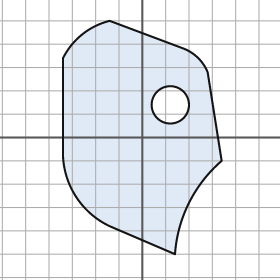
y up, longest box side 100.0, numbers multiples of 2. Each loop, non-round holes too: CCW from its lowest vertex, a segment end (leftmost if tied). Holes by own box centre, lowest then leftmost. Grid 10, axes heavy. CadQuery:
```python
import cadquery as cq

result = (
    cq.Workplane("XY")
    .moveTo(14.0, -50.0)
    .threePointArc((20.0, -28.0), (34.0, -10.0))
    .lineTo(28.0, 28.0)
    .threePointArc((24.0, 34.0), (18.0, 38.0))
    .lineTo(-14.0, 50.0)
    .threePointArc((-26.0, 44.0), (-34.0, 34.0))
    .lineTo(-34.0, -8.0)
    .threePointArc((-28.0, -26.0), (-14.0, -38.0))
    .close()
    .moveTo(12.0, 14.0)
    .circle(8.0)
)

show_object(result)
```